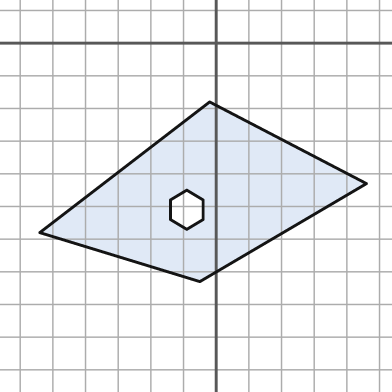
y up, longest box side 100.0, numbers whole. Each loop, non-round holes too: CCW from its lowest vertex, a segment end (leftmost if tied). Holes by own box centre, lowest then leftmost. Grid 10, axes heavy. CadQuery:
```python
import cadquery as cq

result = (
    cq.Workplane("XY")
    .moveTo(-5.0, -73.0)
    .lineTo(46.0, -43.0)
    .lineTo(-2.0, -18.0)
    .lineTo(-54.0, -58.0)
    .close()
    .moveTo(-9.0, -57.0)
    .lineTo(-4.0, -54.0)
    .lineTo(-4.0, -48.0)
    .lineTo(-9.0, -45.0)
    .lineTo(-14.0, -48.0)
    .lineTo(-14.0, -54.0)
    .close()
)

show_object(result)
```